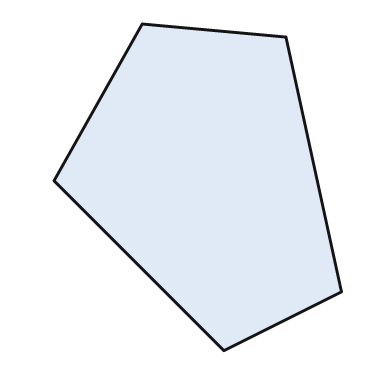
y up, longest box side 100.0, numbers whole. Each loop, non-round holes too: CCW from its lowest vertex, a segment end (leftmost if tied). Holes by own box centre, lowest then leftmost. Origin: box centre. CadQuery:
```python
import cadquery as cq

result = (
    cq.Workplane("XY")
    .moveTo(8.0, -50.0)
    .lineTo(44.0, -32.0)
    .lineTo(27.0, 46.0)
    .lineTo(-17.0, 50.0)
    .lineTo(-44.0, 2.0)
    .close()
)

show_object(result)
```